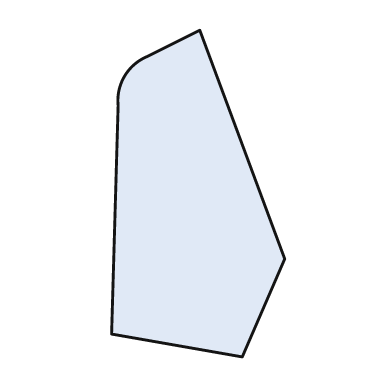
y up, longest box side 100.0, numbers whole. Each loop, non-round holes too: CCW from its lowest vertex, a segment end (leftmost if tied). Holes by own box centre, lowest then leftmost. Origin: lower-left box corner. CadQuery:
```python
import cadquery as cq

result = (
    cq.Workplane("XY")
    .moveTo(40.0, 0.0)
    .lineTo(53.0, 30.0)
    .lineTo(27.0, 100.0)
    .lineTo(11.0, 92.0)
    .threePointArc((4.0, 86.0), (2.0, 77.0))
    .lineTo(0.0, 7.0)
    .close()
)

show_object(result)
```